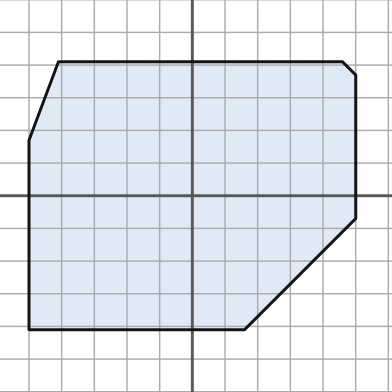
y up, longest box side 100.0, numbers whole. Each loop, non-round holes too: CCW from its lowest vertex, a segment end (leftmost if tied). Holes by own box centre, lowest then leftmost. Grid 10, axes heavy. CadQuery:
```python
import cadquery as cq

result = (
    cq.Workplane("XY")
    .moveTo(-50.0, -41.0)
    .lineTo(16.0, -41.0)
    .lineTo(50.0, -7.0)
    .lineTo(50.0, 37.0)
    .lineTo(46.0, 41.0)
    .lineTo(-41.0, 41.0)
    .lineTo(-50.0, 17.0)
    .close()
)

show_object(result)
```